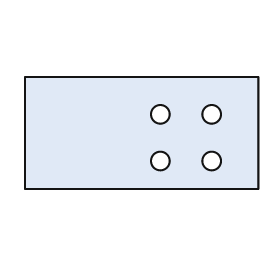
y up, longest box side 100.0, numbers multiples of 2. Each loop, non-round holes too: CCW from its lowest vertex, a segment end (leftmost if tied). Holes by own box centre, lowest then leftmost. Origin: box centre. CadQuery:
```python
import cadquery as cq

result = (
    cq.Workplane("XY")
    .moveTo(-50.0, -24.0)
    .lineTo(50.0, -24.0)
    .lineTo(50.0, 24.0)
    .lineTo(-50.0, 24.0)
    .close()
    .moveTo(8.0, -12.0)
    .circle(4.0)
    .moveTo(30.0, -12.0)
    .circle(4.0)
    .moveTo(8.0, 8.0)
    .circle(4.0)
    .moveTo(30.0, 8.0)
    .circle(4.0)
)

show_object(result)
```